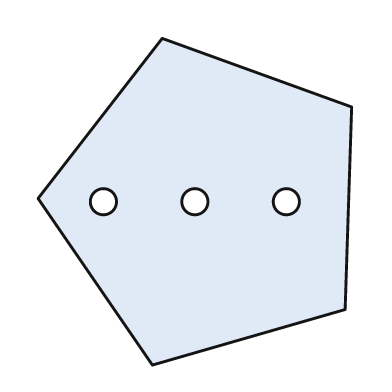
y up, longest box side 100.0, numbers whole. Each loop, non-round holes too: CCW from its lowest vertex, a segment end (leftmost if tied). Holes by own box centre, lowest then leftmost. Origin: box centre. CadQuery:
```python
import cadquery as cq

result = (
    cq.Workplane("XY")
    .moveTo(-13.0, -50.0)
    .lineTo(46.0, -33.0)
    .lineTo(48.0, 29.0)
    .lineTo(-10.0, 50.0)
    .lineTo(-48.0, 1.0)
    .close()
    .moveTo(-28.0, 0.0)
    .circle(4.0)
    .moveTo(0.0, 0.0)
    .circle(4.0)
    .moveTo(28.0, 0.0)
    .circle(4.0)
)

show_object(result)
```